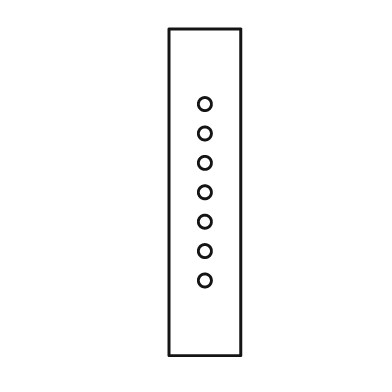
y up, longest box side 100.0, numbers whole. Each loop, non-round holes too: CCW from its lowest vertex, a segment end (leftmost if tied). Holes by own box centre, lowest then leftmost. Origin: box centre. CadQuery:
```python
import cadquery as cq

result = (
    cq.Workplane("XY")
    .moveTo(-11.0, -50.0)
    .lineTo(11.0, -50.0)
    .lineTo(11.0, 50.0)
    .lineTo(-11.0, 50.0)
    .close()
    .moveTo(0.0, -27.0)
    .circle(2.0)
    .moveTo(0.0, -18.0)
    .circle(2.0)
    .moveTo(0.0, -9.0)
    .circle(2.0)
    .moveTo(0.0, 0.0)
    .circle(2.0)
    .moveTo(0.0, 9.0)
    .circle(2.0)
    .moveTo(0.0, 18.0)
    .circle(2.0)
    .moveTo(0.0, 27.0)
    .circle(2.0)
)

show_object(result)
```